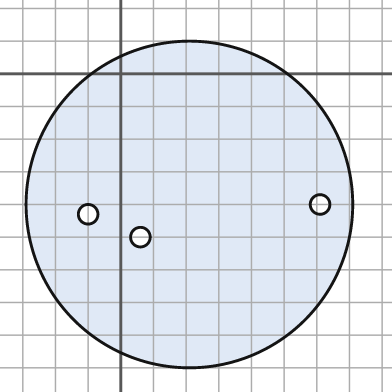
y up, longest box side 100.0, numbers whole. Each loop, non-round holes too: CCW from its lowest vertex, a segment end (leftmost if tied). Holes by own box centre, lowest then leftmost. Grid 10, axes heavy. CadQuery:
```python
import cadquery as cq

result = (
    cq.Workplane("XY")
    .moveTo(21.0, -40.0)
    .circle(50.0)
    .moveTo(6.0, -50.0)
    .circle(3.0)
    .moveTo(-10.0, -43.0)
    .circle(3.0)
    .moveTo(61.0, -40.0)
    .circle(3.0)
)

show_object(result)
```